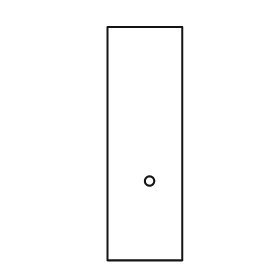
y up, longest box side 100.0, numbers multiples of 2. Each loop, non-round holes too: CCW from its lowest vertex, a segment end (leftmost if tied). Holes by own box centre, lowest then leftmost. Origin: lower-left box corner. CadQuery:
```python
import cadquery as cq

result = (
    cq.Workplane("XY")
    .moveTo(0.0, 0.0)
    .lineTo(32.0, 0.0)
    .lineTo(32.0, 100.0)
    .lineTo(0.0, 100.0)
    .close()
    .moveTo(18.0, 34.0)
    .circle(2.0)
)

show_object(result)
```